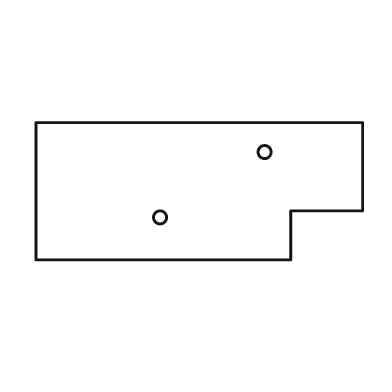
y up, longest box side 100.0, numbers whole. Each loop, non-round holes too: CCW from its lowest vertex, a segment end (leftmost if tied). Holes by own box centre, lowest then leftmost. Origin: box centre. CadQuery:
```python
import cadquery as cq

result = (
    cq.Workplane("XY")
    .moveTo(-50.0, -21.0)
    .lineTo(28.0, -21.0)
    .lineTo(28.0, -6.0)
    .lineTo(50.0, -6.0)
    .lineTo(50.0, 21.0)
    .lineTo(-50.0, 21.0)
    .close()
    .moveTo(-12.0, -8.0)
    .circle(2.0)
    .moveTo(20.0, 12.0)
    .circle(2.0)
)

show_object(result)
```